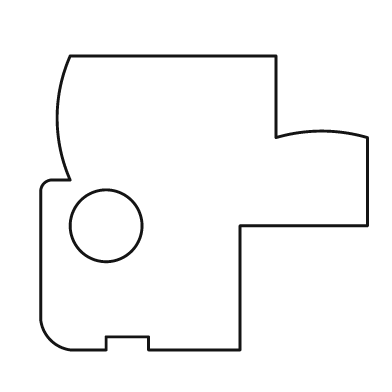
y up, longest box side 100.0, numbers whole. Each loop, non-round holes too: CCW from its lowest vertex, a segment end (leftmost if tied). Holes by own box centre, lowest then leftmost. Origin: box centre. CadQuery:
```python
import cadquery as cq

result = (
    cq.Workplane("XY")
    .moveTo(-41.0, -45.0)
    .lineTo(-30.0, -45.0)
    .lineTo(-30.0, -41.0)
    .lineTo(-17.0, -41.0)
    .lineTo(-17.0, -45.0)
    .lineTo(11.0, -45.0)
    .lineTo(11.0, -7.0)
    .lineTo(50.0, -7.0)
    .lineTo(50.0, 20.0)
    .threePointArc((36.0, 22.0), (22.0, 20.0))
    .lineTo(22.0, 45.0)
    .lineTo(-41.0, 45.0)
    .threePointArc((-45.0, 26.0), (-41.0, 7.0))
    .lineTo(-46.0, 7.0)
    .threePointArc((-49.0, 6.0), (-50.0, 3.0))
    .lineTo(-50.0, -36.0)
    .threePointArc((-47.0, -42.0), (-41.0, -45.0))
    .close()
    .moveTo(-30.0, -7.0)
    .circle(11.0)
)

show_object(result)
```